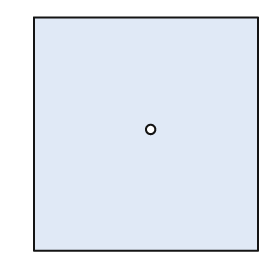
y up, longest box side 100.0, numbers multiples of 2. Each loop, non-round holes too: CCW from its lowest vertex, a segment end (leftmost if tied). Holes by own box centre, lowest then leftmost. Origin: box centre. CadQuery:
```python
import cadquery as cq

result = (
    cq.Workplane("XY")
    .moveTo(-48.0, -50.0)
    .lineTo(48.0, -50.0)
    .lineTo(48.0, 50.0)
    .lineTo(-48.0, 50.0)
    .close()
    .moveTo(2.0, 2.0)
    .circle(2.0)
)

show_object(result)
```